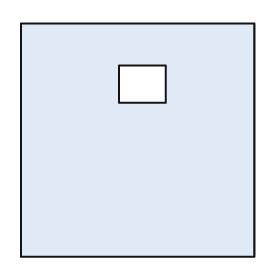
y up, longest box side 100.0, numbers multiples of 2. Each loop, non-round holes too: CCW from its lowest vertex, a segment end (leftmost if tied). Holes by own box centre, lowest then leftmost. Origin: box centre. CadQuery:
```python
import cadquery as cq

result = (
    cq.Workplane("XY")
    .moveTo(-50.0, -50.0)
    .lineTo(50.0, -50.0)
    .lineTo(50.0, 50.0)
    .lineTo(-50.0, 50.0)
    .close()
    .moveTo(-8.0, 16.0)
    .lineTo(12.0, 16.0)
    .lineTo(12.0, 32.0)
    .lineTo(-8.0, 32.0)
    .close()
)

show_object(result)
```